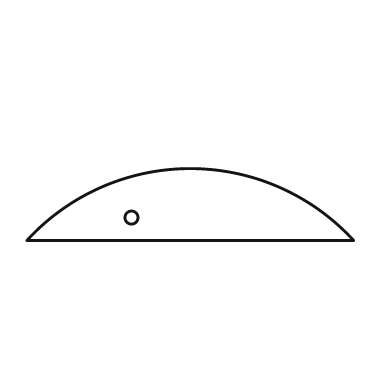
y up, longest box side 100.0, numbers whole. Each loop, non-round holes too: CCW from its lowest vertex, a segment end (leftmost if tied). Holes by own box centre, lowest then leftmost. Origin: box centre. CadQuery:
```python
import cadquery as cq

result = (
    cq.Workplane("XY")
    .moveTo(-50.0, -11.0)
    .lineTo(50.0, -11.0)
    .threePointArc((0.0, 11.0), (-50.0, -11.0))
    .close()
    .moveTo(-18.0, -4.0)
    .circle(2.0)
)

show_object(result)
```